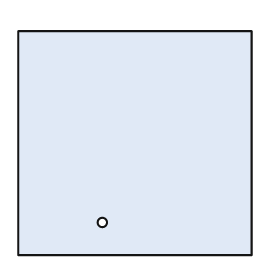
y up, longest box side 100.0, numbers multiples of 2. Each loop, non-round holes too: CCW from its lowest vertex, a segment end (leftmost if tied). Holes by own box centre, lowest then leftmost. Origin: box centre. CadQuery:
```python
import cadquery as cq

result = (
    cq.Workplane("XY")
    .moveTo(-50.0, -48.0)
    .lineTo(50.0, -48.0)
    .lineTo(50.0, 48.0)
    .lineTo(-50.0, 48.0)
    .close()
    .moveTo(-14.0, -34.0)
    .circle(2.0)
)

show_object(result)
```